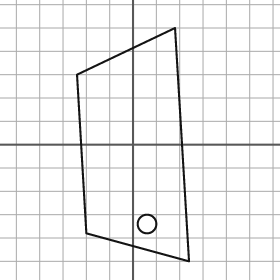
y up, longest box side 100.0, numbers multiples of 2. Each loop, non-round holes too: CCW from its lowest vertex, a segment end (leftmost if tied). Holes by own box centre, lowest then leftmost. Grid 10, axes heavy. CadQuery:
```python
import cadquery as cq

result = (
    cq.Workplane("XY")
    .moveTo(24.0, -50.0)
    .lineTo(18.0, 50.0)
    .lineTo(-24.0, 30.0)
    .lineTo(-20.0, -38.0)
    .close()
    .moveTo(6.0, -34.0)
    .circle(4.0)
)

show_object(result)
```